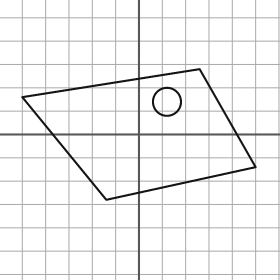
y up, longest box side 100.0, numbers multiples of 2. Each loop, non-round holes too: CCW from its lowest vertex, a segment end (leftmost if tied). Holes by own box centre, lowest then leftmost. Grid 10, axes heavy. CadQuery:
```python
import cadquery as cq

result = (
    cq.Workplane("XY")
    .moveTo(-14.0, -28.0)
    .lineTo(50.0, -14.0)
    .lineTo(26.0, 28.0)
    .lineTo(-50.0, 16.0)
    .close()
    .moveTo(12.0, 14.0)
    .circle(6.0)
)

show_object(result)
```